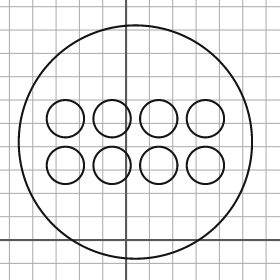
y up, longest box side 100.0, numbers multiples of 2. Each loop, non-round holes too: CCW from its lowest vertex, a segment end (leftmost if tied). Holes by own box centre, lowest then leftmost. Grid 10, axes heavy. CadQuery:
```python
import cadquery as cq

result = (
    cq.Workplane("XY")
    .moveTo(4.0, 42.0)
    .circle(50.0)
    .moveTo(-26.0, 32.0)
    .circle(8.0)
    .moveTo(-6.0, 32.0)
    .circle(8.0)
    .moveTo(14.0, 32.0)
    .circle(8.0)
    .moveTo(34.0, 32.0)
    .circle(8.0)
    .moveTo(-26.0, 52.0)
    .circle(8.0)
    .moveTo(-6.0, 52.0)
    .circle(8.0)
    .moveTo(14.0, 52.0)
    .circle(8.0)
    .moveTo(34.0, 52.0)
    .circle(8.0)
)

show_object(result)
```